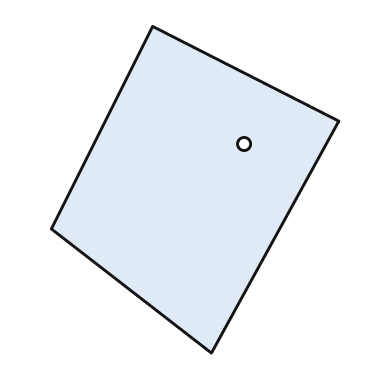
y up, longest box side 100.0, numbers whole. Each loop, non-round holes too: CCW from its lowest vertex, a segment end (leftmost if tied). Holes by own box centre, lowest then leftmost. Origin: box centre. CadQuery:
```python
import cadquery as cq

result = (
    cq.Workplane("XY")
    .moveTo(5.0, -50.0)
    .lineTo(44.0, 21.0)
    .lineTo(-13.0, 50.0)
    .lineTo(-44.0, -12.0)
    .close()
    .moveTo(15.0, 14.0)
    .circle(2.0)
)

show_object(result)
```